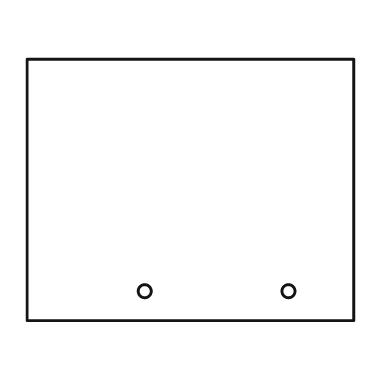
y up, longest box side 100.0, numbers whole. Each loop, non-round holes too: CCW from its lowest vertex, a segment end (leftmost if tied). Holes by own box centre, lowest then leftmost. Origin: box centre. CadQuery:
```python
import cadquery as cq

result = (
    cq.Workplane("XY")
    .moveTo(-50.0, -40.0)
    .lineTo(50.0, -40.0)
    .lineTo(50.0, 40.0)
    .lineTo(-50.0, 40.0)
    .close()
    .moveTo(-14.0, -31.0)
    .circle(2.0)
    .moveTo(30.0, -31.0)
    .circle(2.0)
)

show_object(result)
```